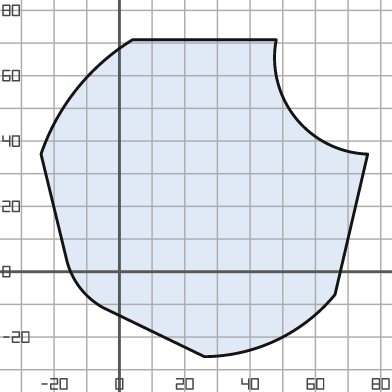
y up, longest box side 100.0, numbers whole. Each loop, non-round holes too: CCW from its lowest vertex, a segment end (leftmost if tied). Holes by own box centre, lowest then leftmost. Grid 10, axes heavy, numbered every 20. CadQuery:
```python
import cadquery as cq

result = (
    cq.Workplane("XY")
    .moveTo(26.0, -26.0)
    .threePointArc((48.0, -21.0), (66.0, -7.0))
    .lineTo(76.0, 36.0)
    .threePointArc((54.0, 47.0), (48.0, 71.0))
    .lineTo(4.0, 71.0)
    .threePointArc((-13.0, 56.0), (-24.0, 36.0))
    .lineTo(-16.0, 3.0)
    .threePointArc((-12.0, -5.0), (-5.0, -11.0))
    .close()
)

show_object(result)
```